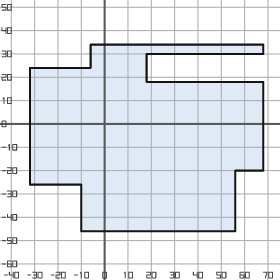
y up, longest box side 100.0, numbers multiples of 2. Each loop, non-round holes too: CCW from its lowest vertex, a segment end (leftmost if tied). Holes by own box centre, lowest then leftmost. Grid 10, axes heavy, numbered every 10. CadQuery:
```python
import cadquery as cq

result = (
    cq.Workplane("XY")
    .moveTo(-10.0, -46.0)
    .lineTo(56.0, -46.0)
    .lineTo(56.0, -20.0)
    .lineTo(68.0, -20.0)
    .lineTo(68.0, 18.0)
    .lineTo(18.0, 18.0)
    .lineTo(18.0, 30.0)
    .lineTo(68.0, 30.0)
    .lineTo(68.0, 34.0)
    .lineTo(-6.0, 34.0)
    .lineTo(-6.0, 24.0)
    .lineTo(-32.0, 24.0)
    .lineTo(-32.0, -26.0)
    .lineTo(-10.0, -26.0)
    .close()
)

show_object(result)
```